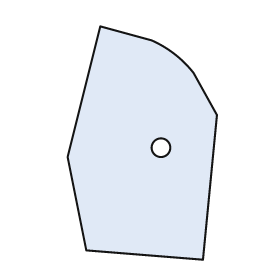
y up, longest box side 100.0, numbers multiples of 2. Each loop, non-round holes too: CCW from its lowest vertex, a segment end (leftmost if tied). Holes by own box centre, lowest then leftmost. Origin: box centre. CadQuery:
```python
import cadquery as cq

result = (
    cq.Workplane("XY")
    .moveTo(26.0, -50.0)
    .lineTo(32.0, 12.0)
    .lineTo(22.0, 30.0)
    .threePointArc((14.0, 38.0), (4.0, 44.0))
    .lineTo(-18.0, 50.0)
    .lineTo(-32.0, -6.0)
    .lineTo(-24.0, -46.0)
    .close()
    .moveTo(8.0, -2.0)
    .circle(4.0)
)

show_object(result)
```